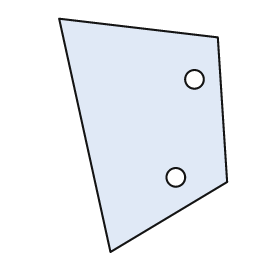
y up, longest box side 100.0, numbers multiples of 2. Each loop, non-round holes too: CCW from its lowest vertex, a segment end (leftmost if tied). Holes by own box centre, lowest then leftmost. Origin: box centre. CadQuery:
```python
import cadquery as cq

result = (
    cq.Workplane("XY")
    .moveTo(-14.0, -50.0)
    .lineTo(36.0, -20.0)
    .lineTo(32.0, 42.0)
    .lineTo(-36.0, 50.0)
    .close()
    .moveTo(14.0, -18.0)
    .circle(4.0)
    .moveTo(22.0, 24.0)
    .circle(4.0)
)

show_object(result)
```